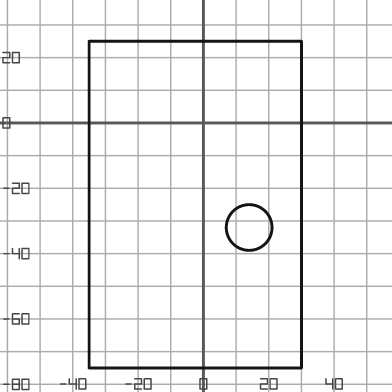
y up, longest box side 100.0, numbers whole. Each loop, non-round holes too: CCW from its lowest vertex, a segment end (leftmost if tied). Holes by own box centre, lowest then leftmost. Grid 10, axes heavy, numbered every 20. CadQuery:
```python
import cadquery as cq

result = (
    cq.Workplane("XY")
    .moveTo(-35.0, -75.0)
    .lineTo(30.0, -75.0)
    .lineTo(30.0, 25.0)
    .lineTo(-35.0, 25.0)
    .close()
    .moveTo(14.0, -32.0)
    .circle(7.0)
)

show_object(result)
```